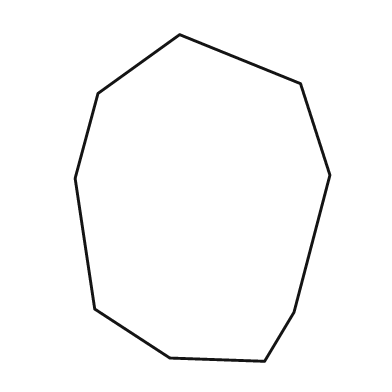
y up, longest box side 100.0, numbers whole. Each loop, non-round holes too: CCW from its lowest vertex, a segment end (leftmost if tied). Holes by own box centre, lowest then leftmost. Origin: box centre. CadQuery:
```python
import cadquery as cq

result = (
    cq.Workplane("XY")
    .moveTo(19.0, -50.0)
    .lineTo(28.0, -35.0)
    .lineTo(39.0, 7.0)
    .lineTo(30.0, 35.0)
    .lineTo(-7.0, 50.0)
    .lineTo(-32.0, 32.0)
    .lineTo(-39.0, 6.0)
    .lineTo(-33.0, -34.0)
    .lineTo(-10.0, -49.0)
    .close()
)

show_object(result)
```